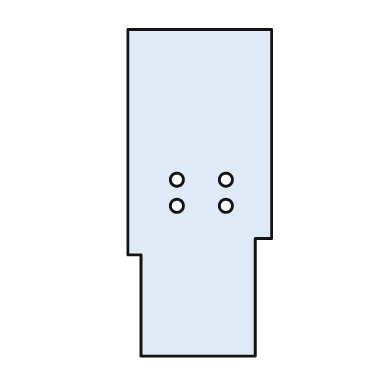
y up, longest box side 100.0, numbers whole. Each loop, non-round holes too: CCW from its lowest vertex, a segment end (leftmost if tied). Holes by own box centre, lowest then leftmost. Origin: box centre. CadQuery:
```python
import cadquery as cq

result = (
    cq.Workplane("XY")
    .moveTo(-18.0, -50.0)
    .lineTo(17.0, -50.0)
    .lineTo(17.0, -14.0)
    .lineTo(22.0, -14.0)
    .lineTo(22.0, 50.0)
    .lineTo(-22.0, 50.0)
    .lineTo(-22.0, -19.0)
    .lineTo(-18.0, -19.0)
    .close()
    .moveTo(-7.0, -4.0)
    .circle(2.0)
    .moveTo(8.0, -4.0)
    .circle(2.0)
    .moveTo(-7.0, 4.0)
    .circle(2.0)
    .moveTo(8.0, 4.0)
    .circle(2.0)
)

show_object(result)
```